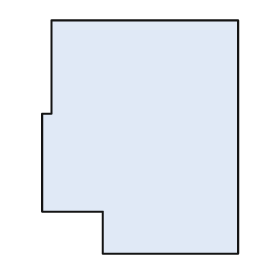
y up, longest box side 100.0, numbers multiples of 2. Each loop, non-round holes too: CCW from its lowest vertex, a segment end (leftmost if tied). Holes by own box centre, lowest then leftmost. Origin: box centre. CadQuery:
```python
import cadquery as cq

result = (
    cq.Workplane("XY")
    .moveTo(-16.0, -50.0)
    .lineTo(42.0, -50.0)
    .lineTo(42.0, 50.0)
    .lineTo(-38.0, 50.0)
    .lineTo(-38.0, 10.0)
    .lineTo(-42.0, 10.0)
    .lineTo(-42.0, -32.0)
    .lineTo(-16.0, -32.0)
    .close()
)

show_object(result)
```